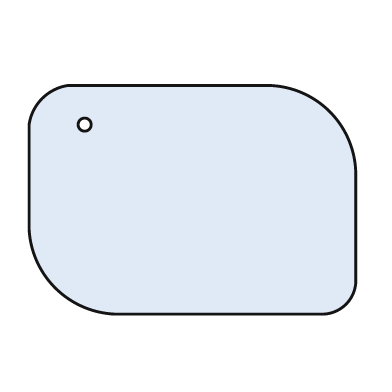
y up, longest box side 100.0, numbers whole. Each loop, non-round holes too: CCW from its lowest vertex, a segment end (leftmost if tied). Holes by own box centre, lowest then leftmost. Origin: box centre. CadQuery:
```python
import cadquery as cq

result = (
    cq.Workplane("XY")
    .moveTo(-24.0, -35.0)
    .lineTo(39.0, -35.0)
    .threePointArc((47.0, -32.0), (50.0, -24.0))
    .lineTo(50.0, 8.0)
    .threePointArc((42.0, 27.0), (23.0, 35.0))
    .lineTo(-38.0, 35.0)
    .threePointArc((-46.0, 31.0), (-50.0, 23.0))
    .lineTo(-50.0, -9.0)
    .threePointArc((-42.0, -27.0), (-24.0, -35.0))
    .close()
    .moveTo(-33.0, 23.0)
    .circle(2.0)
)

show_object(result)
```